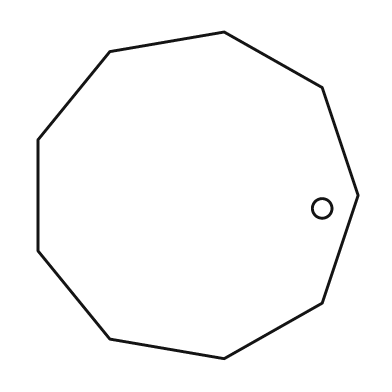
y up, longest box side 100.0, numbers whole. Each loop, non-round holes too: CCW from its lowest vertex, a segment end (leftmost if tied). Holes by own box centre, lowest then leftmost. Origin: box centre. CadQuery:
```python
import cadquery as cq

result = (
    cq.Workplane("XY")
    .moveTo(8.0, -50.0)
    .lineTo(38.0, -33.0)
    .lineTo(49.0, 0.0)
    .lineTo(38.0, 33.0)
    .lineTo(8.0, 50.0)
    .lineTo(-27.0, 44.0)
    .lineTo(-49.0, 17.0)
    .lineTo(-49.0, -17.0)
    .lineTo(-27.0, -44.0)
    .close()
    .moveTo(38.0, -4.0)
    .circle(3.0)
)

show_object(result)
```